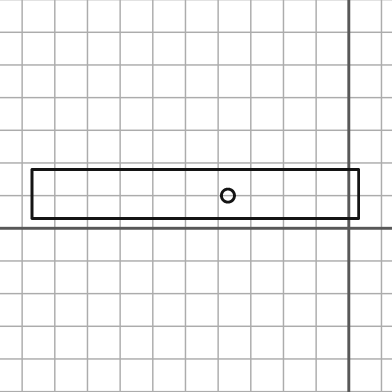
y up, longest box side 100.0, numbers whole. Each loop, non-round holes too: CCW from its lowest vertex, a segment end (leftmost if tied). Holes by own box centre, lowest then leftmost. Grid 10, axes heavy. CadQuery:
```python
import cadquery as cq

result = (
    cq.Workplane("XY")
    .moveTo(-97.0, 3.0)
    .lineTo(3.0, 3.0)
    .lineTo(3.0, 18.0)
    .lineTo(-97.0, 18.0)
    .close()
    .moveTo(-37.0, 10.0)
    .circle(2.0)
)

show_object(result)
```